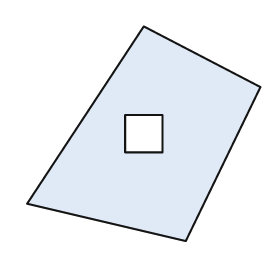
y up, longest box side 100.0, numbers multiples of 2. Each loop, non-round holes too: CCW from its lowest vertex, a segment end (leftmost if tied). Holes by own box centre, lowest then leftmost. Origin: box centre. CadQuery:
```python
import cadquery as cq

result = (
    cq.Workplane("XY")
    .moveTo(18.0, -46.0)
    .lineTo(50.0, 20.0)
    .lineTo(0.0, 46.0)
    .lineTo(-50.0, -30.0)
    .close()
    .moveTo(-8.0, -8.0)
    .lineTo(8.0, -8.0)
    .lineTo(8.0, 8.0)
    .lineTo(-8.0, 8.0)
    .close()
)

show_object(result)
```